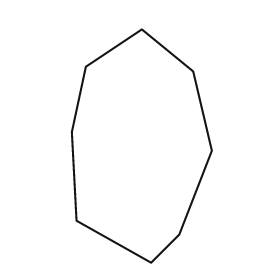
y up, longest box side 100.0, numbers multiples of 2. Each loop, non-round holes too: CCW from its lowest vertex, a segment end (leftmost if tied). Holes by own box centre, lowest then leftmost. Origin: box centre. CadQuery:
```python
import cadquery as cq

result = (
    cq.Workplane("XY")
    .moveTo(4.0, -50.0)
    .lineTo(16.0, -38.0)
    .lineTo(30.0, -2.0)
    .lineTo(22.0, 32.0)
    .lineTo(0.0, 50.0)
    .lineTo(-24.0, 34.0)
    .lineTo(-30.0, 6.0)
    .lineTo(-28.0, -32.0)
    .close()
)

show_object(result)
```